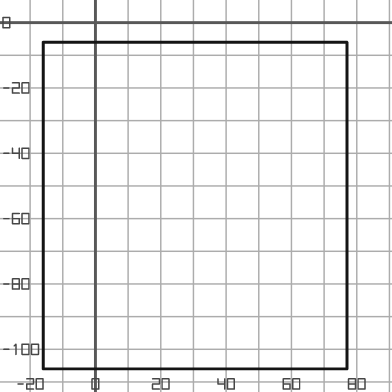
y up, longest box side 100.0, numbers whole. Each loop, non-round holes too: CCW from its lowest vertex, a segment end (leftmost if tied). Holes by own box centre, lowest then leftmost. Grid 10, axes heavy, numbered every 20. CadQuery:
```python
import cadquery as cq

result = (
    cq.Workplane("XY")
    .moveTo(-16.0, -106.0)
    .lineTo(77.0, -106.0)
    .lineTo(77.0, -6.0)
    .lineTo(-16.0, -6.0)
    .close()
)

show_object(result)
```